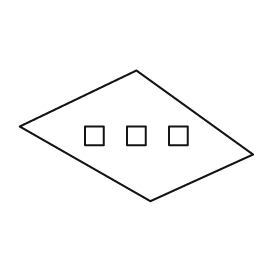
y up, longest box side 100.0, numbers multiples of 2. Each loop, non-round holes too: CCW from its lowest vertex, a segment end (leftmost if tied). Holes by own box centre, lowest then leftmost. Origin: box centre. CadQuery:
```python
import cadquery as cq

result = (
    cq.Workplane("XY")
    .moveTo(6.0, -28.0)
    .lineTo(50.0, -8.0)
    .lineTo(0.0, 28.0)
    .lineTo(-50.0, 4.0)
    .close()
    .moveTo(-22.0, -4.0)
    .lineTo(-14.0, -4.0)
    .lineTo(-14.0, 4.0)
    .lineTo(-22.0, 4.0)
    .close()
    .moveTo(-4.0, -4.0)
    .lineTo(4.0, -4.0)
    .lineTo(4.0, 4.0)
    .lineTo(-4.0, 4.0)
    .close()
    .moveTo(14.0, -4.0)
    .lineTo(22.0, -4.0)
    .lineTo(22.0, 4.0)
    .lineTo(14.0, 4.0)
    .close()
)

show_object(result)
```